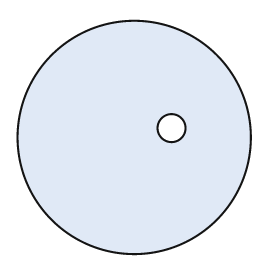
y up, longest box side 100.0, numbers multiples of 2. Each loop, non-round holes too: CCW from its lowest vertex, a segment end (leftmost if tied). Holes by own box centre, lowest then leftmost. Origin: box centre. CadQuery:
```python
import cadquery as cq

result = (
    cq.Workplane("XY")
    .moveTo(0.0, 0.0)
    .circle(50.0)
    .moveTo(16.0, 4.0)
    .circle(6.0)
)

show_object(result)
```